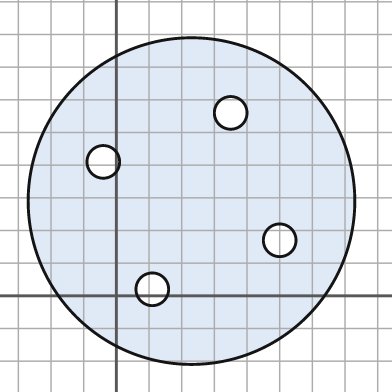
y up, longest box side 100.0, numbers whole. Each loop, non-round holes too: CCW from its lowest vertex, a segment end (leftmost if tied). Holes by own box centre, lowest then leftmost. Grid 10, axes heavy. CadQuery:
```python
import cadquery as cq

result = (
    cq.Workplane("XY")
    .moveTo(23.0, 29.0)
    .circle(50.0)
    .moveTo(11.0, 2.0)
    .circle(5.0)
    .moveTo(50.0, 17.0)
    .circle(5.0)
    .moveTo(-4.0, 41.0)
    .circle(5.0)
    .moveTo(35.0, 56.0)
    .circle(5.0)
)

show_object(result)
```